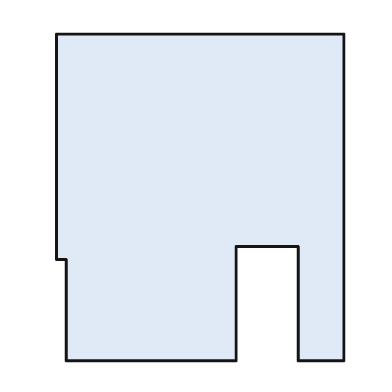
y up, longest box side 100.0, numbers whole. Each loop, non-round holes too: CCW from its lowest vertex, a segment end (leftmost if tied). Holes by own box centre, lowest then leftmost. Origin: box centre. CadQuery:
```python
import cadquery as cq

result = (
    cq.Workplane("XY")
    .moveTo(-41.0, -50.0)
    .lineTo(11.0, -50.0)
    .lineTo(11.0, -15.0)
    .lineTo(30.0, -15.0)
    .lineTo(30.0, -50.0)
    .lineTo(44.0, -50.0)
    .lineTo(44.0, 50.0)
    .lineTo(-44.0, 50.0)
    .lineTo(-44.0, -19.0)
    .lineTo(-41.0, -19.0)
    .close()
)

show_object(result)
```